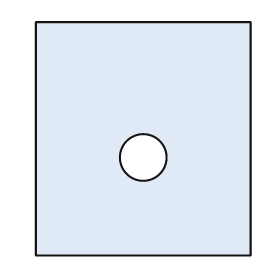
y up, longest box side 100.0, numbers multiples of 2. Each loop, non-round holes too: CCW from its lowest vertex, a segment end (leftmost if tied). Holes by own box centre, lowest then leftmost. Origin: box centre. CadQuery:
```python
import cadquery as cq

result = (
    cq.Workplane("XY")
    .moveTo(-46.0, -50.0)
    .lineTo(46.0, -50.0)
    .lineTo(46.0, 50.0)
    .lineTo(-46.0, 50.0)
    .close()
    .moveTo(0.0, -8.0)
    .circle(10.0)
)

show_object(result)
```